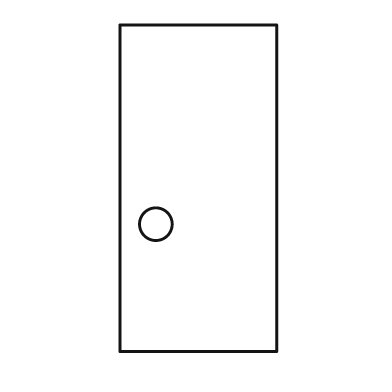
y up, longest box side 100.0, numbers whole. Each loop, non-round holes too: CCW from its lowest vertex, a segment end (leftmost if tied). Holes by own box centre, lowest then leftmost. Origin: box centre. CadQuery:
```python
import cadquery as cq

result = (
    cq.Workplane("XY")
    .moveTo(-24.0, -50.0)
    .lineTo(24.0, -50.0)
    .lineTo(24.0, 50.0)
    .lineTo(-24.0, 50.0)
    .close()
    .moveTo(-13.0, -11.0)
    .circle(5.0)
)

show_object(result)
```